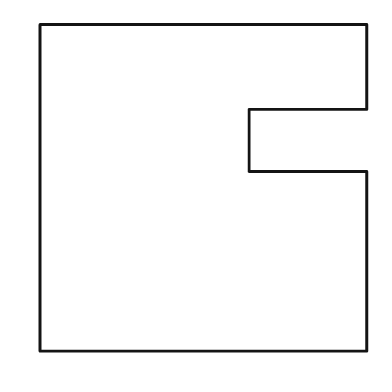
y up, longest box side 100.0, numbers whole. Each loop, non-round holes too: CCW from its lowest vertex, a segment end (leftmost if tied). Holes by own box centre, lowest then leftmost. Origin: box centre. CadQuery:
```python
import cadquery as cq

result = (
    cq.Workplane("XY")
    .moveTo(-50.0, -50.0)
    .lineTo(50.0, -50.0)
    .lineTo(50.0, 5.0)
    .lineTo(14.0, 5.0)
    .lineTo(14.0, 24.0)
    .lineTo(50.0, 24.0)
    .lineTo(50.0, 50.0)
    .lineTo(-50.0, 50.0)
    .close()
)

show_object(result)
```